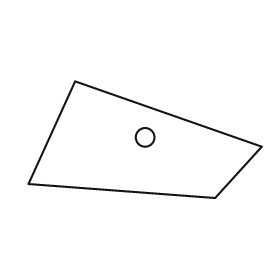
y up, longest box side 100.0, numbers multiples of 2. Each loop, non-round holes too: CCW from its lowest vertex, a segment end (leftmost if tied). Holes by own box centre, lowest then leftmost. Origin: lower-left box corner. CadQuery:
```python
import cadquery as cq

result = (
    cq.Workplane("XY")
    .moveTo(80.0, 0.0)
    .lineTo(100.0, 22.0)
    .lineTo(20.0, 50.0)
    .lineTo(0.0, 6.0)
    .close()
    .moveTo(50.0, 26.0)
    .circle(4.0)
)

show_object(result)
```